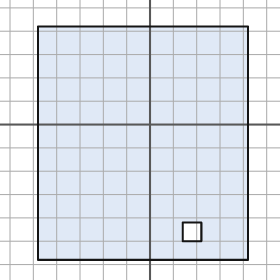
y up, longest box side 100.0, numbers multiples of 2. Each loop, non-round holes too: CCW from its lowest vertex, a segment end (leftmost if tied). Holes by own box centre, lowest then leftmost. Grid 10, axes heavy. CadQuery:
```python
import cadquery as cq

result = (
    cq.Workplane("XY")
    .moveTo(-48.0, -58.0)
    .lineTo(42.0, -58.0)
    .lineTo(42.0, 42.0)
    .lineTo(-48.0, 42.0)
    .close()
    .moveTo(14.0, -50.0)
    .lineTo(22.0, -50.0)
    .lineTo(22.0, -42.0)
    .lineTo(14.0, -42.0)
    .close()
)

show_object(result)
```